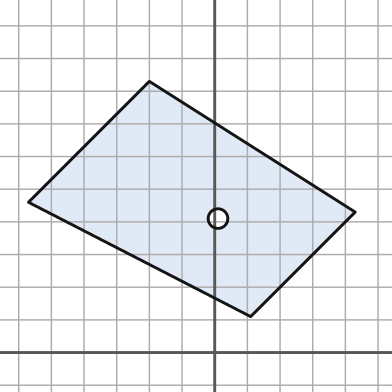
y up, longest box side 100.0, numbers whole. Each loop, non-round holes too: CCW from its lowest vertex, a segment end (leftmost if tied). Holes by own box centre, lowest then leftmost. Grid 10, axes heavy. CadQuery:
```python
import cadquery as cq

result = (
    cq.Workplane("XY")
    .moveTo(11.0, 11.0)
    .lineTo(43.0, 43.0)
    .lineTo(-20.0, 83.0)
    .lineTo(-57.0, 46.0)
    .close()
    .moveTo(1.0, 41.0)
    .circle(3.0)
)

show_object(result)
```